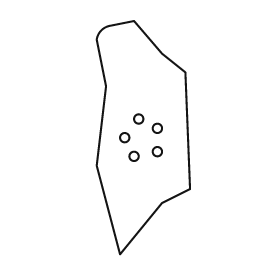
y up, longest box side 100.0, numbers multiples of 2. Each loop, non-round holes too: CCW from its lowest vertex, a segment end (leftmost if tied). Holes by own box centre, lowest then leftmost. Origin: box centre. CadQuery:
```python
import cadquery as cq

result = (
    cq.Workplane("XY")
    .moveTo(-10.0, -50.0)
    .lineTo(8.0, -28.0)
    .lineTo(20.0, -22.0)
    .lineTo(18.0, 28.0)
    .lineTo(8.0, 36.0)
    .lineTo(-4.0, 50.0)
    .lineTo(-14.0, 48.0)
    .threePointArc((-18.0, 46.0), (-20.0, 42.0))
    .lineTo(-16.0, 22.0)
    .lineTo(-20.0, -12.0)
    .close()
    .moveTo(-4.0, -8.0)
    .circle(2.0)
    .moveTo(6.0, -6.0)
    .circle(2.0)
    .moveTo(-8.0, 0.0)
    .circle(2.0)
    .moveTo(6.0, 4.0)
    .circle(2.0)
    .moveTo(-2.0, 8.0)
    .circle(2.0)
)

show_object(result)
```